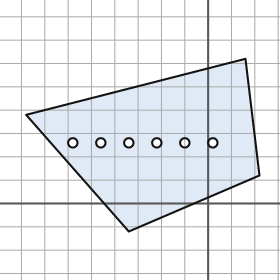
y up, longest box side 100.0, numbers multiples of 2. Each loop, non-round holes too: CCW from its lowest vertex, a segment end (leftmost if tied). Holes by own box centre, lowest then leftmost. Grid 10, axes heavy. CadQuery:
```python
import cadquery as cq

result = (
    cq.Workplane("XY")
    .moveTo(-34.0, -12.0)
    .lineTo(22.0, 12.0)
    .lineTo(16.0, 62.0)
    .lineTo(-78.0, 38.0)
    .close()
    .moveTo(-58.0, 26.0)
    .circle(2.0)
    .moveTo(-46.0, 26.0)
    .circle(2.0)
    .moveTo(-34.0, 26.0)
    .circle(2.0)
    .moveTo(-22.0, 26.0)
    .circle(2.0)
    .moveTo(-10.0, 26.0)
    .circle(2.0)
    .moveTo(2.0, 26.0)
    .circle(2.0)
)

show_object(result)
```